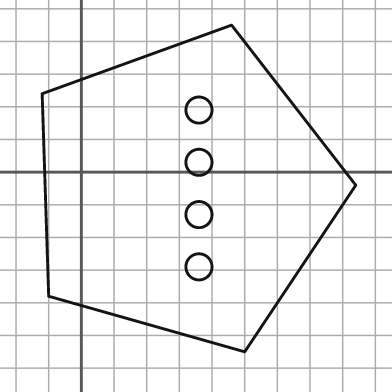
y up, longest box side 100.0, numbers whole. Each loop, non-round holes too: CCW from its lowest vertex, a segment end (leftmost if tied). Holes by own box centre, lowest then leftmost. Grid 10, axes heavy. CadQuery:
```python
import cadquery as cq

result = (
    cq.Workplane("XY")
    .moveTo(50.0, -55.0)
    .lineTo(84.0, -4.0)
    .lineTo(46.0, 45.0)
    .lineTo(-12.0, 24.0)
    .lineTo(-10.0, -38.0)
    .close()
    .moveTo(36.0, -29.0)
    .circle(4.0)
    .moveTo(36.0, -13.0)
    .circle(4.0)
    .moveTo(36.0, 3.0)
    .circle(4.0)
    .moveTo(36.0, 19.0)
    .circle(4.0)
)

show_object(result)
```